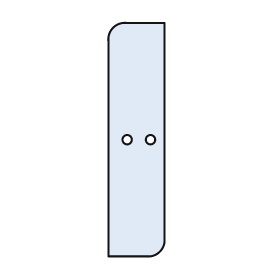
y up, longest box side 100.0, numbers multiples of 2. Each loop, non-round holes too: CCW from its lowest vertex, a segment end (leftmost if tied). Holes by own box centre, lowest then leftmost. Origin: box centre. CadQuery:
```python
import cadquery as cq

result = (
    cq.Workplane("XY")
    .moveTo(-12.0, -50.0)
    .lineTo(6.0, -50.0)
    .threePointArc((10.0, -48.0), (12.0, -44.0))
    .lineTo(12.0, 50.0)
    .lineTo(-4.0, 50.0)
    .threePointArc((-10.0, 48.0), (-12.0, 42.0))
    .close()
    .moveTo(-4.0, 0.0)
    .circle(2.0)
    .moveTo(6.0, 0.0)
    .circle(2.0)
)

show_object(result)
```